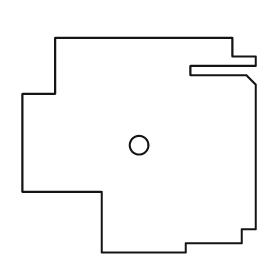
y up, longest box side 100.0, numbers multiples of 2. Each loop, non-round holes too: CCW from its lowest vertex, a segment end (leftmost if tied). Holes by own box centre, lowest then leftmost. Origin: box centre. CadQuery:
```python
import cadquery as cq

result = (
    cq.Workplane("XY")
    .moveTo(-16.0, -46.0)
    .lineTo(20.0, -46.0)
    .lineTo(20.0, -42.0)
    .lineTo(44.0, -42.0)
    .lineTo(44.0, -36.0)
    .lineTo(50.0, -36.0)
    .lineTo(50.0, 26.0)
    .lineTo(46.0, 30.0)
    .lineTo(22.0, 30.0)
    .lineTo(22.0, 34.0)
    .lineTo(50.0, 34.0)
    .lineTo(50.0, 38.0)
    .lineTo(40.0, 38.0)
    .lineTo(40.0, 46.0)
    .lineTo(-36.0, 46.0)
    .lineTo(-36.0, 22.0)
    .lineTo(-50.0, 22.0)
    .lineTo(-50.0, -20.0)
    .lineTo(-16.0, -20.0)
    .close()
    .moveTo(0.0, 0.0)
    .circle(4.0)
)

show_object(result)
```